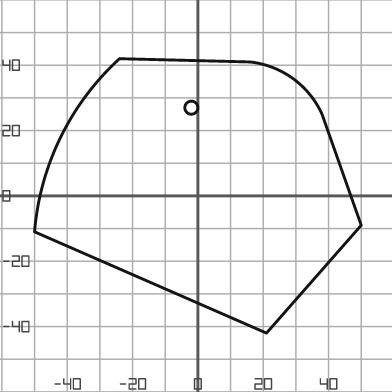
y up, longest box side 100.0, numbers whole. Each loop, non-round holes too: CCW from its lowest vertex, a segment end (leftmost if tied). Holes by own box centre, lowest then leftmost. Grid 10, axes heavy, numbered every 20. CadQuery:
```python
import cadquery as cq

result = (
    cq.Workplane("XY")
    .moveTo(21.0, -42.0)
    .lineTo(50.0, -9.0)
    .lineTo(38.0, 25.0)
    .threePointArc((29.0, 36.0), (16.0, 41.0))
    .lineTo(-24.0, 42.0)
    .threePointArc((-42.0, 18.0), (-50.0, -11.0))
    .close()
    .moveTo(-2.0, 27.0)
    .circle(2.0)
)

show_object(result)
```